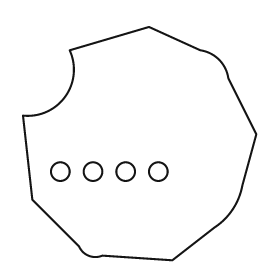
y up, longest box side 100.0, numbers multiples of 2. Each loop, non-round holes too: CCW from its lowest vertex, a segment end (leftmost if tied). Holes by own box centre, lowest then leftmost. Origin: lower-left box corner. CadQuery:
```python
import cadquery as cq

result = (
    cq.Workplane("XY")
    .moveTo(64.0, 0.0)
    .lineTo(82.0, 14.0)
    .threePointArc((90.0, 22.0), (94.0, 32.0))
    .lineTo(100.0, 54.0)
    .lineTo(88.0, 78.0)
    .threePointArc((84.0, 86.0), (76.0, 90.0))
    .lineTo(54.0, 100.0)
    .lineTo(20.0, 90.0)
    .threePointArc((18.0, 70.0), (0.0, 62.0))
    .lineTo(4.0, 26.0)
    .lineTo(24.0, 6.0)
    .threePointArc((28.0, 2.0), (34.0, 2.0))
    .close()
    .moveTo(16.0, 38.0)
    .circle(4.0)
    .moveTo(30.0, 38.0)
    .circle(4.0)
    .moveTo(44.0, 38.0)
    .circle(4.0)
    .moveTo(58.0, 38.0)
    .circle(4.0)
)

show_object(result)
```